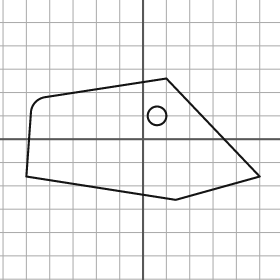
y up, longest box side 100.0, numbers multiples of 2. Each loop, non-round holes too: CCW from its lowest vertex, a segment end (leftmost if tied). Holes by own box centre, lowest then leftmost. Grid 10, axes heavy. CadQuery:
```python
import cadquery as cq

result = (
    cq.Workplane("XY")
    .moveTo(14.0, -26.0)
    .lineTo(50.0, -16.0)
    .lineTo(10.0, 26.0)
    .lineTo(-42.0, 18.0)
    .threePointArc((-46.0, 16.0), (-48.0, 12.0))
    .lineTo(-50.0, -16.0)
    .close()
    .moveTo(6.0, 10.0)
    .circle(4.0)
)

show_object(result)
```